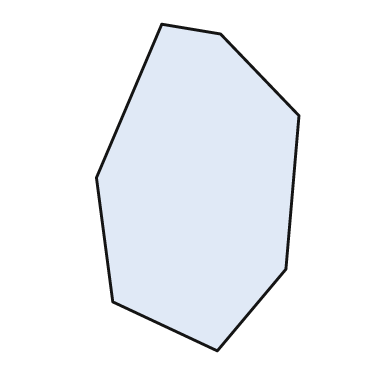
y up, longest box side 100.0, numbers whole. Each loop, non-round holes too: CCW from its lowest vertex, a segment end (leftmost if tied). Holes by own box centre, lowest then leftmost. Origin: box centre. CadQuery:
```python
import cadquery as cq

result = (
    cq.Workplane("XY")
    .moveTo(6.0, -50.0)
    .lineTo(27.0, -25.0)
    .lineTo(31.0, 22.0)
    .lineTo(7.0, 47.0)
    .lineTo(-11.0, 50.0)
    .lineTo(-31.0, 3.0)
    .lineTo(-26.0, -35.0)
    .close()
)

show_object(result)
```